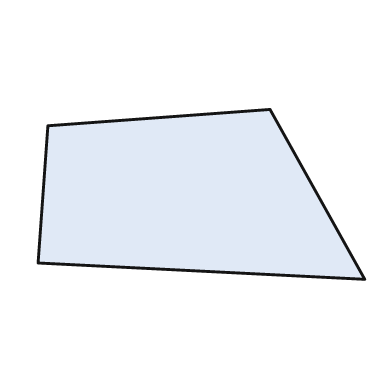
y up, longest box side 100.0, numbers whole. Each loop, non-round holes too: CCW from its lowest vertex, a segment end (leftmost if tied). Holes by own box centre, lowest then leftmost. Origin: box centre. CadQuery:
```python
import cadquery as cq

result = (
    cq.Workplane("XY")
    .moveTo(50.0, -26.0)
    .lineTo(21.0, 26.0)
    .lineTo(-47.0, 21.0)
    .lineTo(-50.0, -21.0)
    .close()
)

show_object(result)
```